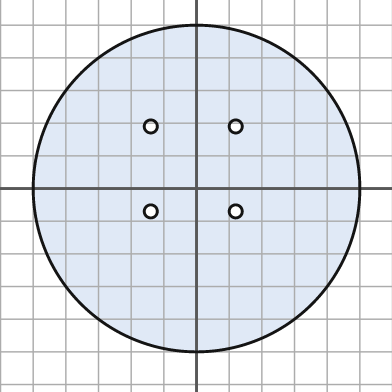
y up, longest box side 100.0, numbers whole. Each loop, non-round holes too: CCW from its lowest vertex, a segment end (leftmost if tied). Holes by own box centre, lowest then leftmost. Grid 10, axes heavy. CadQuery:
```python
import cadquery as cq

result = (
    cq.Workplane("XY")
    .moveTo(0.0, 0.0)
    .circle(50.0)
    .moveTo(-14.0, -7.0)
    .circle(2.0)
    .moveTo(12.0, -7.0)
    .circle(2.0)
    .moveTo(-14.0, 19.0)
    .circle(2.0)
    .moveTo(12.0, 19.0)
    .circle(2.0)
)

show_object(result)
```